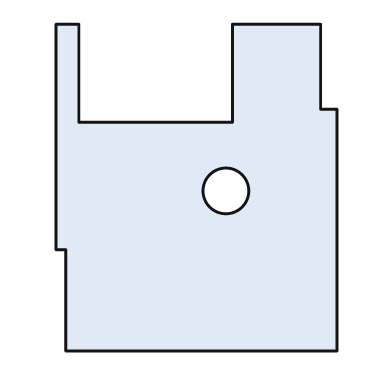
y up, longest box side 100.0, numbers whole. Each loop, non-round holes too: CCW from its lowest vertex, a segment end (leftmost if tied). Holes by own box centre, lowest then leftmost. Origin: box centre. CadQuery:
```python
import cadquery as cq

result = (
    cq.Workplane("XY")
    .moveTo(-40.0, -50.0)
    .lineTo(43.0, -50.0)
    .lineTo(43.0, 24.0)
    .lineTo(38.0, 24.0)
    .lineTo(38.0, 50.0)
    .lineTo(11.0, 50.0)
    .lineTo(11.0, 20.0)
    .lineTo(-36.0, 20.0)
    .lineTo(-36.0, 50.0)
    .lineTo(-43.0, 50.0)
    .lineTo(-43.0, -19.0)
    .lineTo(-40.0, -19.0)
    .close()
    .moveTo(9.0, -1.0)
    .circle(7.0)
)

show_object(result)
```